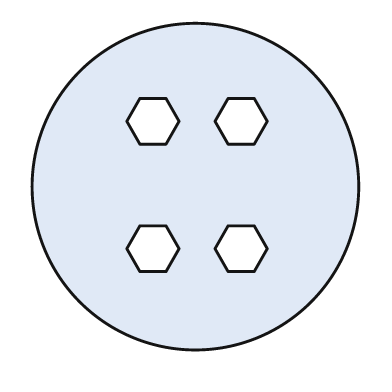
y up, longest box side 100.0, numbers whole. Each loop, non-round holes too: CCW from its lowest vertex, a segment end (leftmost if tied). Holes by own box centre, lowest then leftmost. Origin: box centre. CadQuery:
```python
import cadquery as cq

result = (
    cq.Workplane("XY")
    .moveTo(0.0, 0.0)
    .circle(50.0)
    .moveTo(-17.0, -26.0)
    .lineTo(-9.0, -26.0)
    .lineTo(-5.0, -19.0)
    .lineTo(-9.0, -12.0)
    .lineTo(-17.0, -12.0)
    .lineTo(-21.0, -19.0)
    .close()
    .moveTo(10.0, -26.0)
    .lineTo(18.0, -26.0)
    .lineTo(22.0, -19.0)
    .lineTo(18.0, -12.0)
    .lineTo(10.0, -12.0)
    .lineTo(6.0, -19.0)
    .close()
    .moveTo(-17.0, 13.0)
    .lineTo(-9.0, 13.0)
    .lineTo(-5.0, 20.0)
    .lineTo(-9.0, 27.0)
    .lineTo(-17.0, 27.0)
    .lineTo(-21.0, 20.0)
    .close()
    .moveTo(10.0, 13.0)
    .lineTo(18.0, 13.0)
    .lineTo(22.0, 20.0)
    .lineTo(18.0, 27.0)
    .lineTo(10.0, 27.0)
    .lineTo(6.0, 20.0)
    .close()
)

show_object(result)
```